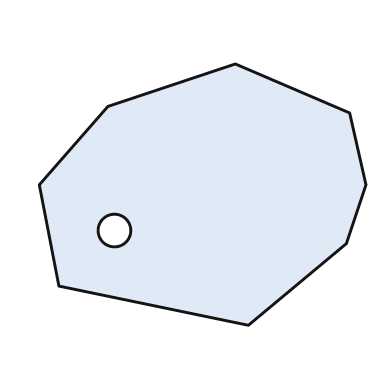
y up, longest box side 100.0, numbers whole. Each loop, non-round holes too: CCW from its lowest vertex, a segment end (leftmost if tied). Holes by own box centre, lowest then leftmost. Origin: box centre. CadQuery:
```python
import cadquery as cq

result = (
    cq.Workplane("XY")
    .moveTo(14.0, -40.0)
    .lineTo(44.0, -15.0)
    .lineTo(50.0, 3.0)
    .lineTo(45.0, 25.0)
    .lineTo(10.0, 40.0)
    .lineTo(-29.0, 27.0)
    .lineTo(-50.0, 3.0)
    .lineTo(-44.0, -28.0)
    .close()
    .moveTo(-27.0, -11.0)
    .circle(5.0)
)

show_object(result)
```